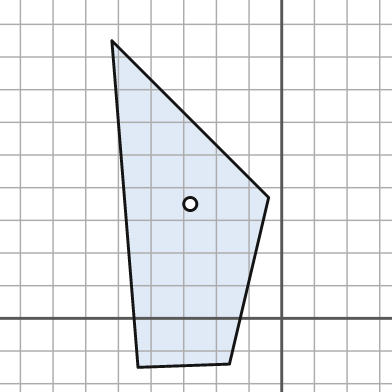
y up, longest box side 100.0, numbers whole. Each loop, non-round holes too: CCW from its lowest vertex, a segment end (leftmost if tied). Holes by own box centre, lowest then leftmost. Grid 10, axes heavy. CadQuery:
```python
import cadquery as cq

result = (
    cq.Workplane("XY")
    .moveTo(-44.0, -15.0)
    .lineTo(-16.0, -14.0)
    .lineTo(-4.0, 37.0)
    .lineTo(-52.0, 85.0)
    .close()
    .moveTo(-28.0, 35.0)
    .circle(2.0)
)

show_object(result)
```